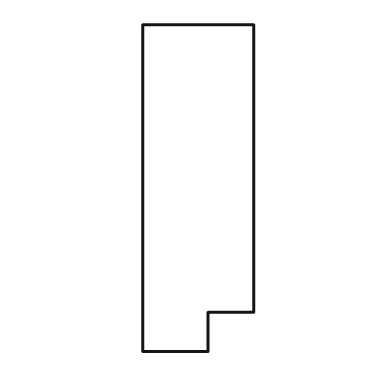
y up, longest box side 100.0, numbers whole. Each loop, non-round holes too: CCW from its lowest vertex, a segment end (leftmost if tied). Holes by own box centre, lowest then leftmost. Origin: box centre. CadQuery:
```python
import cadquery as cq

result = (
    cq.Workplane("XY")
    .moveTo(-17.0, -50.0)
    .lineTo(3.0, -50.0)
    .lineTo(3.0, -38.0)
    .lineTo(17.0, -38.0)
    .lineTo(17.0, 50.0)
    .lineTo(-17.0, 50.0)
    .close()
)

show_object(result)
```